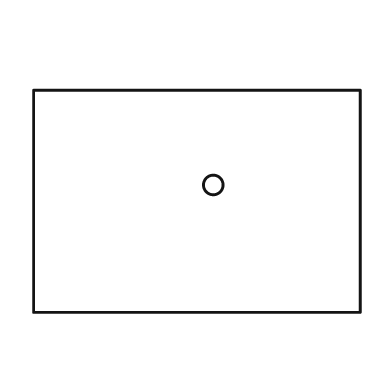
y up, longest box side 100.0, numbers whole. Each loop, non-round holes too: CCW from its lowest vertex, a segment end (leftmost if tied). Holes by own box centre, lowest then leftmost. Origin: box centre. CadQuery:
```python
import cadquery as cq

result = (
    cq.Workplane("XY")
    .moveTo(-50.0, -34.0)
    .lineTo(50.0, -34.0)
    .lineTo(50.0, 34.0)
    .lineTo(-50.0, 34.0)
    .close()
    .moveTo(5.0, 5.0)
    .circle(3.0)
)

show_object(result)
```